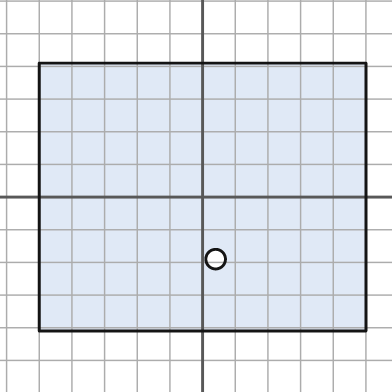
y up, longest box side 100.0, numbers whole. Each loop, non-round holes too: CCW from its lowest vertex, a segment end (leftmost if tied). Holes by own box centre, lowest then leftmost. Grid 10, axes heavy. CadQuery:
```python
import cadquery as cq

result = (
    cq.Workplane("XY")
    .moveTo(-50.0, -41.0)
    .lineTo(50.0, -41.0)
    .lineTo(50.0, 41.0)
    .lineTo(-50.0, 41.0)
    .close()
    .moveTo(4.0, -19.0)
    .circle(3.0)
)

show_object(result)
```